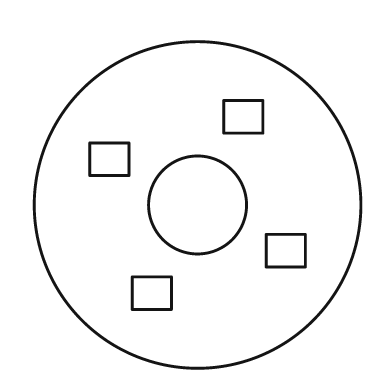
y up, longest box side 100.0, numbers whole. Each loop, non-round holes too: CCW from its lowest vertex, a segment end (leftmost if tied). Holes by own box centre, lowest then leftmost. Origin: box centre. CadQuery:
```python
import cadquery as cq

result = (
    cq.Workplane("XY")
    .moveTo(0.0, 0.0)
    .circle(50.0)
    .moveTo(-20.0, -32.0)
    .lineTo(-8.0, -32.0)
    .lineTo(-8.0, -22.0)
    .lineTo(-20.0, -22.0)
    .close()
    .moveTo(21.0, -19.0)
    .lineTo(33.0, -19.0)
    .lineTo(33.0, -9.0)
    .lineTo(21.0, -9.0)
    .close()
    .moveTo(0.0, 0.0)
    .circle(15.0)
    .moveTo(-33.0, 9.0)
    .lineTo(-21.0, 9.0)
    .lineTo(-21.0, 19.0)
    .lineTo(-33.0, 19.0)
    .close()
    .moveTo(8.0, 22.0)
    .lineTo(20.0, 22.0)
    .lineTo(20.0, 32.0)
    .lineTo(8.0, 32.0)
    .close()
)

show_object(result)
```